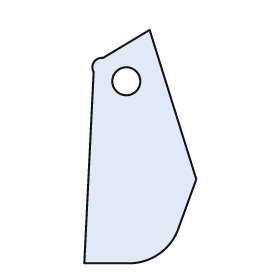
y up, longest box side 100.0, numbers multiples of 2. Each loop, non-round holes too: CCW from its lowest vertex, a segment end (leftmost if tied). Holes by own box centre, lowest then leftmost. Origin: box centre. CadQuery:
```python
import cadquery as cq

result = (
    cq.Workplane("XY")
    .moveTo(-24.0, -50.0)
    .lineTo(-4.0, -50.0)
    .threePointArc((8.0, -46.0), (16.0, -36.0))
    .lineTo(24.0, -14.0)
    .lineTo(4.0, 50.0)
    .lineTo(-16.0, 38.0)
    .threePointArc((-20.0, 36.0), (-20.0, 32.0))
    .close()
    .moveTo(-6.0, 28.0)
    .circle(6.0)
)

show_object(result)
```